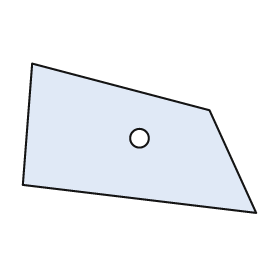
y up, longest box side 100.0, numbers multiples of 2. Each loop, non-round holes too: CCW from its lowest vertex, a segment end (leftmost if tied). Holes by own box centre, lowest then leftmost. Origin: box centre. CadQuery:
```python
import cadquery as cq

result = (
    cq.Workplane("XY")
    .moveTo(50.0, -32.0)
    .lineTo(30.0, 12.0)
    .lineTo(-46.0, 32.0)
    .lineTo(-50.0, -20.0)
    .close()
    .moveTo(0.0, 0.0)
    .circle(4.0)
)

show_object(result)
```